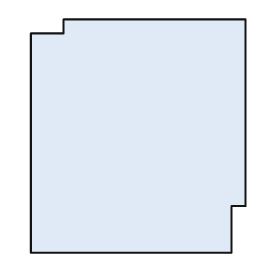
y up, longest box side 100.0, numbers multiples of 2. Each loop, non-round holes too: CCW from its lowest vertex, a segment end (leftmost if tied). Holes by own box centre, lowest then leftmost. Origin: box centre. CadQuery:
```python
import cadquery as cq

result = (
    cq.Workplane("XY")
    .moveTo(-46.0, -50.0)
    .lineTo(40.0, -50.0)
    .lineTo(40.0, -30.0)
    .lineTo(46.0, -30.0)
    .lineTo(46.0, 50.0)
    .lineTo(-32.0, 50.0)
    .lineTo(-32.0, 44.0)
    .lineTo(-46.0, 44.0)
    .close()
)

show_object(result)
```